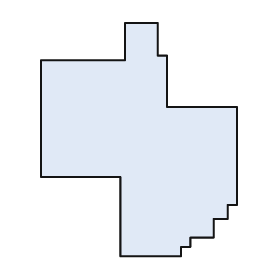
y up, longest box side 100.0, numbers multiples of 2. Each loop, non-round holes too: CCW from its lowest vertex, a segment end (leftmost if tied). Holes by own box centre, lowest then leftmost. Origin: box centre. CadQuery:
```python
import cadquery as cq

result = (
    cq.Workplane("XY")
    .moveTo(-8.0, -50.0)
    .lineTo(18.0, -50.0)
    .lineTo(18.0, -46.0)
    .lineTo(22.0, -46.0)
    .lineTo(22.0, -42.0)
    .lineTo(32.0, -42.0)
    .lineTo(32.0, -34.0)
    .lineTo(38.0, -34.0)
    .lineTo(38.0, -28.0)
    .lineTo(42.0, -28.0)
    .lineTo(42.0, 14.0)
    .lineTo(12.0, 14.0)
    .lineTo(12.0, 36.0)
    .lineTo(8.0, 36.0)
    .lineTo(8.0, 50.0)
    .lineTo(-6.0, 50.0)
    .lineTo(-6.0, 34.0)
    .lineTo(-42.0, 34.0)
    .lineTo(-42.0, -16.0)
    .lineTo(-8.0, -16.0)
    .close()
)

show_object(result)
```